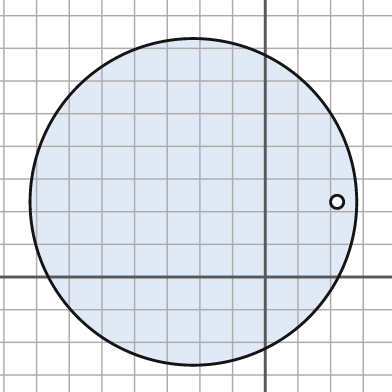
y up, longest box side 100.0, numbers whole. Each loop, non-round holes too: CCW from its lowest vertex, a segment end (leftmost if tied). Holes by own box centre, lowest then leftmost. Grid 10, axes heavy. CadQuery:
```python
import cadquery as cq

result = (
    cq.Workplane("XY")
    .moveTo(-22.0, 23.0)
    .circle(50.0)
    .moveTo(22.0, 23.0)
    .circle(2.0)
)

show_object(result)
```